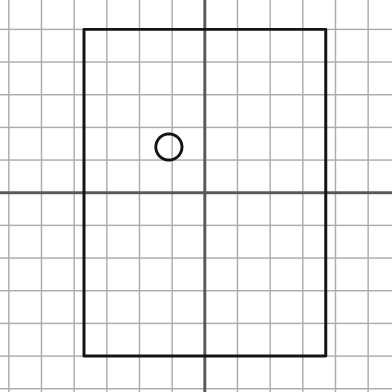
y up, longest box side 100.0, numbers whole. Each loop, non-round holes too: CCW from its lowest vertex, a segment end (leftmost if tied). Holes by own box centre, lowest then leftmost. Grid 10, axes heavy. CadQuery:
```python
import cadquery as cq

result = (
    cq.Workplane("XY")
    .moveTo(-37.0, -50.0)
    .lineTo(37.0, -50.0)
    .lineTo(37.0, 50.0)
    .lineTo(-37.0, 50.0)
    .close()
    .moveTo(-11.0, 14.0)
    .circle(4.0)
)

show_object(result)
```